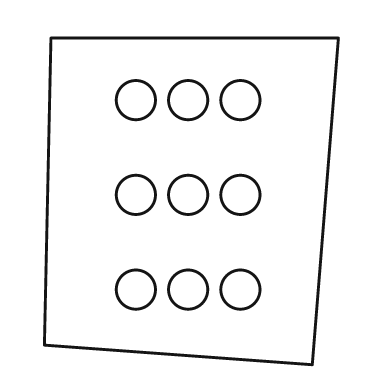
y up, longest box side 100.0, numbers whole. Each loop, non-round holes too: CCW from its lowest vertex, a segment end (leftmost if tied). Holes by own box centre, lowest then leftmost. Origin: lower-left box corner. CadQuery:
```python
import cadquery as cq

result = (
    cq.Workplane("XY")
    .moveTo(82.0, 0.0)
    .lineTo(90.0, 100.0)
    .lineTo(2.0, 100.0)
    .lineTo(0.0, 6.0)
    .close()
    .moveTo(28.0, 23.0)
    .circle(6.0)
    .moveTo(44.0, 23.0)
    .circle(6.0)
    .moveTo(60.0, 23.0)
    .circle(6.0)
    .moveTo(28.0, 52.0)
    .circle(6.0)
    .moveTo(44.0, 52.0)
    .circle(6.0)
    .moveTo(60.0, 52.0)
    .circle(6.0)
    .moveTo(28.0, 81.0)
    .circle(6.0)
    .moveTo(44.0, 81.0)
    .circle(6.0)
    .moveTo(60.0, 81.0)
    .circle(6.0)
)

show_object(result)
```